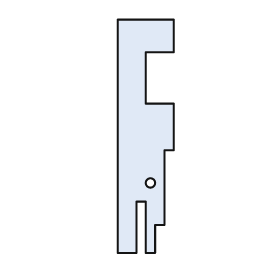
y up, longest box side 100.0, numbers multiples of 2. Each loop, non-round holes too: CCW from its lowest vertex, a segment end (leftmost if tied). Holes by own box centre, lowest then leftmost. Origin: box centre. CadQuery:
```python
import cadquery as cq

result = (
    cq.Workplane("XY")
    .moveTo(-12.0, -50.0)
    .lineTo(-4.0, -50.0)
    .lineTo(-4.0, -28.0)
    .lineTo(0.0, -28.0)
    .lineTo(0.0, -50.0)
    .lineTo(4.0, -50.0)
    .lineTo(4.0, -38.0)
    .lineTo(8.0, -38.0)
    .lineTo(8.0, -6.0)
    .lineTo(12.0, -6.0)
    .lineTo(12.0, 14.0)
    .lineTo(0.0, 14.0)
    .lineTo(0.0, 36.0)
    .lineTo(12.0, 36.0)
    .lineTo(12.0, 50.0)
    .lineTo(-12.0, 50.0)
    .close()
    .moveTo(2.0, -20.0)
    .circle(2.0)
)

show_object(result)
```